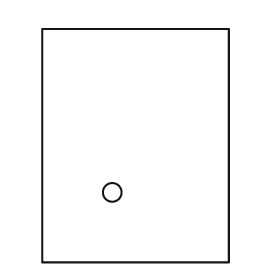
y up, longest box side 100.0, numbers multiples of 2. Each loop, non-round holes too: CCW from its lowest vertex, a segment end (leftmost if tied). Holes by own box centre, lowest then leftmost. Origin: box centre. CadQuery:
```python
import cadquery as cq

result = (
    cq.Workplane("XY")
    .moveTo(-40.0, -50.0)
    .lineTo(40.0, -50.0)
    .lineTo(40.0, 50.0)
    .lineTo(-40.0, 50.0)
    .close()
    .moveTo(-10.0, -20.0)
    .circle(4.0)
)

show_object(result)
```